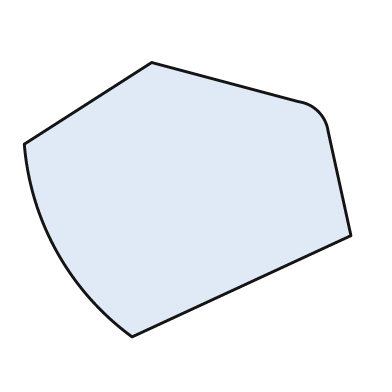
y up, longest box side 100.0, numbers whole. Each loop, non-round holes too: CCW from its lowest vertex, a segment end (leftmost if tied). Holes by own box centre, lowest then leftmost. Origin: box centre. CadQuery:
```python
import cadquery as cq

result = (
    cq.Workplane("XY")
    .moveTo(-17.0, -42.0)
    .lineTo(50.0, -11.0)
    .lineTo(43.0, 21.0)
    .threePointArc((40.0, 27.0), (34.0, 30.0))
    .lineTo(-11.0, 42.0)
    .lineTo(-50.0, 17.0)
    .threePointArc((-40.0, -16.0), (-17.0, -42.0))
    .close()
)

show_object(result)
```